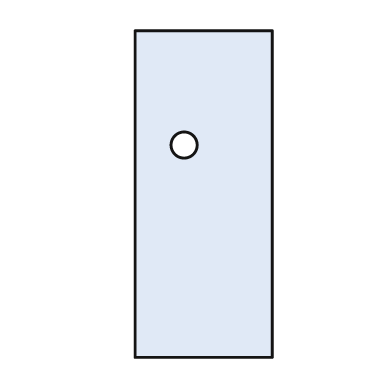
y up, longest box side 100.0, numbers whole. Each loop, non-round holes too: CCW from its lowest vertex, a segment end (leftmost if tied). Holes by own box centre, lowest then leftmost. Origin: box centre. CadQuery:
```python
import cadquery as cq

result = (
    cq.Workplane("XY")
    .moveTo(-21.0, -50.0)
    .lineTo(21.0, -50.0)
    .lineTo(21.0, 50.0)
    .lineTo(-21.0, 50.0)
    .close()
    .moveTo(-6.0, 15.0)
    .circle(4.0)
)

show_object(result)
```